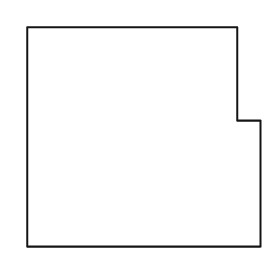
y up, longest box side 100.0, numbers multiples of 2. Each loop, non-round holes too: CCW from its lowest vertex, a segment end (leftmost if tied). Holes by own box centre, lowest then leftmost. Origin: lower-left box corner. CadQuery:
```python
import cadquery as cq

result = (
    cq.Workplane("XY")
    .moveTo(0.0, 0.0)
    .lineTo(100.0, 0.0)
    .lineTo(100.0, 54.0)
    .lineTo(90.0, 54.0)
    .lineTo(90.0, 94.0)
    .lineTo(0.0, 94.0)
    .close()
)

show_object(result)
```